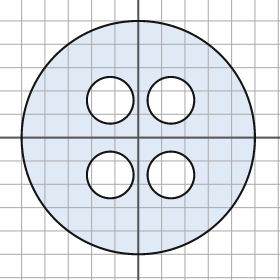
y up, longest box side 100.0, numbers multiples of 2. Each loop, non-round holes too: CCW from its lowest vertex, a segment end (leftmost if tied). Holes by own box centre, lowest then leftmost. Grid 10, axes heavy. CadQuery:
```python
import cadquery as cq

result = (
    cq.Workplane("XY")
    .moveTo(0.0, 0.0)
    .circle(50.0)
    .moveTo(-12.0, -16.0)
    .circle(10.0)
    .moveTo(14.0, -16.0)
    .circle(10.0)
    .moveTo(-12.0, 16.0)
    .circle(10.0)
    .moveTo(14.0, 16.0)
    .circle(10.0)
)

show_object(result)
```